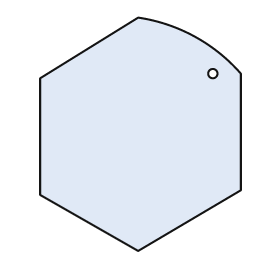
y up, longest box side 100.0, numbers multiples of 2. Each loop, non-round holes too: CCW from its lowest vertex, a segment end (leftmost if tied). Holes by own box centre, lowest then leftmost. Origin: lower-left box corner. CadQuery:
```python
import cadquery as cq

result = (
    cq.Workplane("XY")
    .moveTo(42.0, 0.0)
    .lineTo(86.0, 26.0)
    .lineTo(86.0, 76.0)
    .threePointArc((66.0, 92.0), (42.0, 100.0))
    .lineTo(0.0, 74.0)
    .lineTo(0.0, 24.0)
    .close()
    .moveTo(74.0, 76.0)
    .circle(2.0)
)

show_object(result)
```